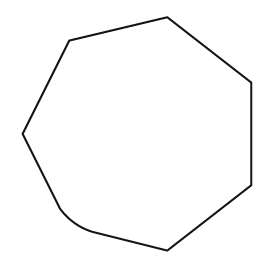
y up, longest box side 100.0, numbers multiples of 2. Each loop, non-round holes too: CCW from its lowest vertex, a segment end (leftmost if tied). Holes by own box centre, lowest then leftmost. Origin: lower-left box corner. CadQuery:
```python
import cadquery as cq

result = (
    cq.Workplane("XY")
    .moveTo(62.0, 0.0)
    .lineTo(98.0, 28.0)
    .lineTo(98.0, 72.0)
    .lineTo(62.0, 100.0)
    .lineTo(20.0, 90.0)
    .lineTo(0.0, 50.0)
    .lineTo(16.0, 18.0)
    .threePointArc((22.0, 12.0), (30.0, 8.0))
    .close()
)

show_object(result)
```